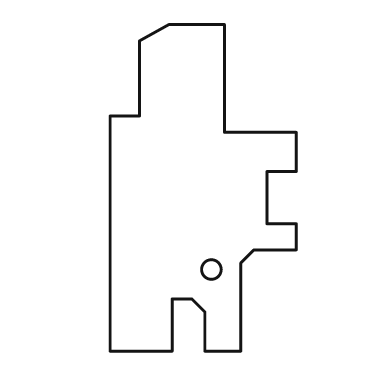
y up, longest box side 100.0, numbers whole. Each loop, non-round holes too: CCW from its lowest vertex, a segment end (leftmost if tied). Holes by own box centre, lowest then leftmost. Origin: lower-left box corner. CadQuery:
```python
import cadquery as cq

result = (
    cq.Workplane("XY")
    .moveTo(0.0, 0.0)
    .lineTo(19.0, 0.0)
    .lineTo(19.0, 16.0)
    .lineTo(25.0, 16.0)
    .lineTo(29.0, 12.0)
    .lineTo(29.0, 0.0)
    .lineTo(40.0, 0.0)
    .lineTo(40.0, 27.0)
    .lineTo(44.0, 31.0)
    .lineTo(57.0, 31.0)
    .lineTo(57.0, 39.0)
    .lineTo(48.0, 39.0)
    .lineTo(48.0, 55.0)
    .lineTo(57.0, 55.0)
    .lineTo(57.0, 67.0)
    .lineTo(35.0, 67.0)
    .lineTo(35.0, 100.0)
    .lineTo(18.0, 100.0)
    .lineTo(9.0, 95.0)
    .lineTo(9.0, 72.0)
    .lineTo(0.0, 72.0)
    .close()
    .moveTo(31.0, 25.0)
    .circle(3.0)
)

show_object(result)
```